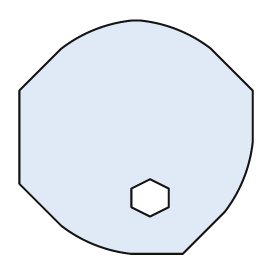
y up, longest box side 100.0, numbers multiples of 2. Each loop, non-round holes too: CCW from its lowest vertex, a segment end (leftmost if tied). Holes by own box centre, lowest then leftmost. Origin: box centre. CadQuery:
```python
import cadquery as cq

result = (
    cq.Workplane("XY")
    .moveTo(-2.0, -50.0)
    .lineTo(20.0, -50.0)
    .lineTo(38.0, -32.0)
    .threePointArc((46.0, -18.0), (50.0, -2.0))
    .lineTo(50.0, 20.0)
    .lineTo(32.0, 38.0)
    .threePointArc((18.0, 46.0), (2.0, 50.0))
    .lineTo(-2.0, 50.0)
    .threePointArc((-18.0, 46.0), (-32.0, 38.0))
    .lineTo(-50.0, 20.0)
    .lineTo(-50.0, -20.0)
    .lineTo(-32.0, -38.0)
    .threePointArc((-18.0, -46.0), (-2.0, -50.0))
    .close()
    .moveTo(6.0, -34.0)
    .lineTo(14.0, -30.0)
    .lineTo(14.0, -22.0)
    .lineTo(6.0, -18.0)
    .lineTo(-2.0, -22.0)
    .lineTo(-2.0, -30.0)
    .close()
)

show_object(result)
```